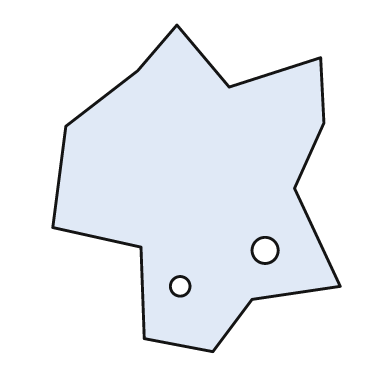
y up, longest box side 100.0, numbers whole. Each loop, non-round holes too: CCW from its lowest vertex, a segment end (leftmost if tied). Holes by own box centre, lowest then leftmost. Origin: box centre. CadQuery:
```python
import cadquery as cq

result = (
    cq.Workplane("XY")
    .moveTo(5.0, -50.0)
    .lineTo(17.0, -34.0)
    .lineTo(44.0, -30.0)
    .lineTo(30.0, 0.0)
    .lineTo(39.0, 20.0)
    .lineTo(38.0, 40.0)
    .lineTo(10.0, 31.0)
    .lineTo(-6.0, 50.0)
    .lineTo(-18.0, 36.0)
    .lineTo(-40.0, 19.0)
    .lineTo(-44.0, -12.0)
    .lineTo(-17.0, -18.0)
    .lineTo(-16.0, -46.0)
    .close()
    .moveTo(-5.0, -30.0)
    .circle(3.0)
    .moveTo(21.0, -19.0)
    .circle(4.0)
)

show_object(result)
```